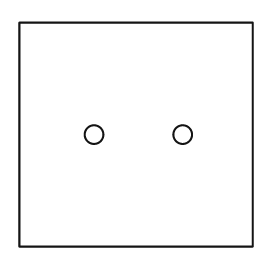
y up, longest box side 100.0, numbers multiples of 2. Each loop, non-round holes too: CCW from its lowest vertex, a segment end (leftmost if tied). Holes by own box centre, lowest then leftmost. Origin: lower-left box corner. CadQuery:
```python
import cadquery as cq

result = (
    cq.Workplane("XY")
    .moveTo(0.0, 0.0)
    .lineTo(100.0, 0.0)
    .lineTo(100.0, 96.0)
    .lineTo(0.0, 96.0)
    .close()
    .moveTo(32.0, 48.0)
    .circle(4.0)
    .moveTo(70.0, 48.0)
    .circle(4.0)
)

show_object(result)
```